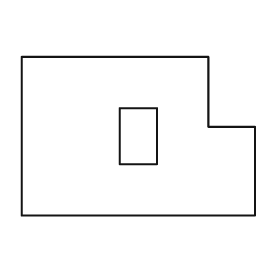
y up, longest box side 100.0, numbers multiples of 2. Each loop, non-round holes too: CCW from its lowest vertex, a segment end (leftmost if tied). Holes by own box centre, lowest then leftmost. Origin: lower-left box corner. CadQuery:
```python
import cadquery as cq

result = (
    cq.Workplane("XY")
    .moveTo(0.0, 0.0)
    .lineTo(100.0, 0.0)
    .lineTo(100.0, 38.0)
    .lineTo(80.0, 38.0)
    .lineTo(80.0, 68.0)
    .lineTo(0.0, 68.0)
    .close()
    .moveTo(42.0, 22.0)
    .lineTo(58.0, 22.0)
    .lineTo(58.0, 46.0)
    .lineTo(42.0, 46.0)
    .close()
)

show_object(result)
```